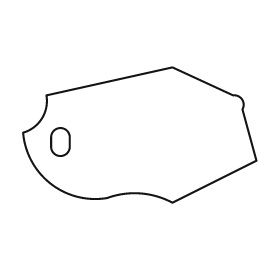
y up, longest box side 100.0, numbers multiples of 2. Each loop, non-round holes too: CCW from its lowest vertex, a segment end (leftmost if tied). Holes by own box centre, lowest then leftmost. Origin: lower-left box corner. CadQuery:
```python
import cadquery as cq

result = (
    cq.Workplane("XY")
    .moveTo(64.0, 0.0)
    .lineTo(100.0, 18.0)
    .lineTo(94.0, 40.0)
    .threePointArc((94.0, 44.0), (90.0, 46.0))
    .lineTo(64.0, 58.0)
    .lineTo(10.0, 46.0)
    .threePointArc((8.0, 36.0), (0.0, 30.0))
    .threePointArc((12.0, 8.0), (36.0, 2.0))
    .threePointArc((50.0, 4.0), (64.0, 0.0))
    .close()
    .moveTo(12.0, 24.0)
    .threePointArc((16.0, 20.0), (20.0, 24.0))
    .lineTo(20.0, 28.0)
    .threePointArc((16.0, 32.0), (12.0, 28.0))
    .close()
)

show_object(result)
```